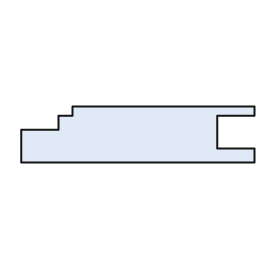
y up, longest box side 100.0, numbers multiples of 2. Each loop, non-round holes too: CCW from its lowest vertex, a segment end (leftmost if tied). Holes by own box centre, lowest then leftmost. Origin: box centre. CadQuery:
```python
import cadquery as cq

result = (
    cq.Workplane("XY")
    .moveTo(-50.0, -12.0)
    .lineTo(50.0, -12.0)
    .lineTo(50.0, -6.0)
    .lineTo(34.0, -6.0)
    .lineTo(34.0, 8.0)
    .lineTo(50.0, 8.0)
    .lineTo(50.0, 12.0)
    .lineTo(-28.0, 12.0)
    .lineTo(-28.0, 8.0)
    .lineTo(-34.0, 8.0)
    .lineTo(-34.0, 2.0)
    .lineTo(-50.0, 2.0)
    .close()
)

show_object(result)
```